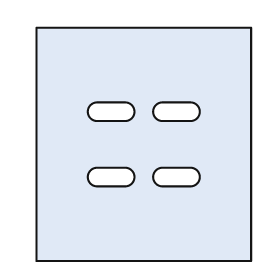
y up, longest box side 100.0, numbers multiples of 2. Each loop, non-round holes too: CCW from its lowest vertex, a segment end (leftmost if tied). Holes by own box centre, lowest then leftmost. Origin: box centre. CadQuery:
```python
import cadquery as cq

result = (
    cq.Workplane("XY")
    .moveTo(-46.0, -50.0)
    .lineTo(46.0, -50.0)
    .lineTo(46.0, 50.0)
    .lineTo(-46.0, 50.0)
    .close()
    .moveTo(-20.0, -18.0)
    .lineTo(-8.0, -18.0)
    .threePointArc((-4.0, -14.0), (-8.0, -10.0))
    .lineTo(-20.0, -10.0)
    .threePointArc((-24.0, -14.0), (-20.0, -18.0))
    .close()
    .moveTo(8.0, -18.0)
    .lineTo(20.0, -18.0)
    .threePointArc((24.0, -14.0), (20.0, -10.0))
    .lineTo(8.0, -10.0)
    .threePointArc((4.0, -14.0), (8.0, -18.0))
    .close()
    .moveTo(-20.0, 10.0)
    .lineTo(-8.0, 10.0)
    .threePointArc((-4.0, 14.0), (-8.0, 18.0))
    .lineTo(-20.0, 18.0)
    .threePointArc((-24.0, 14.0), (-20.0, 10.0))
    .close()
    .moveTo(8.0, 10.0)
    .lineTo(20.0, 10.0)
    .threePointArc((24.0, 14.0), (20.0, 18.0))
    .lineTo(8.0, 18.0)
    .threePointArc((4.0, 14.0), (8.0, 10.0))
    .close()
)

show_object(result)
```